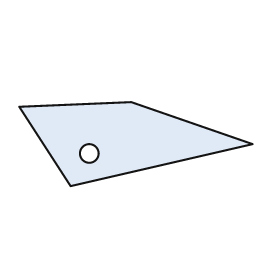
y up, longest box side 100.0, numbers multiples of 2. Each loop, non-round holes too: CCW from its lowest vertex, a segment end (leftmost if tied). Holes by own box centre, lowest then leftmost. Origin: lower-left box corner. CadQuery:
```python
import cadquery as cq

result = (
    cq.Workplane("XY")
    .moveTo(22.0, 0.0)
    .lineTo(100.0, 18.0)
    .lineTo(48.0, 36.0)
    .lineTo(0.0, 34.0)
    .close()
    .moveTo(30.0, 14.0)
    .circle(4.0)
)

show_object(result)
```